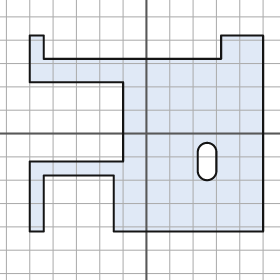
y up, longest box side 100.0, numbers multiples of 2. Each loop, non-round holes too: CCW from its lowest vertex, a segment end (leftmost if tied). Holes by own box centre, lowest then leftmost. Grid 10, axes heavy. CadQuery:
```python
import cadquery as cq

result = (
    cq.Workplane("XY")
    .moveTo(-50.0, -42.0)
    .lineTo(-44.0, -42.0)
    .lineTo(-44.0, -18.0)
    .lineTo(-14.0, -18.0)
    .lineTo(-14.0, -42.0)
    .lineTo(50.0, -42.0)
    .lineTo(50.0, 42.0)
    .lineTo(32.0, 42.0)
    .lineTo(32.0, 32.0)
    .lineTo(-44.0, 32.0)
    .lineTo(-44.0, 42.0)
    .lineTo(-50.0, 42.0)
    .lineTo(-50.0, 22.0)
    .lineTo(-10.0, 22.0)
    .lineTo(-10.0, -12.0)
    .lineTo(-50.0, -12.0)
    .close()
    .moveTo(22.0, -16.0)
    .threePointArc((26.0, -20.0), (30.0, -16.0))
    .lineTo(30.0, -8.0)
    .threePointArc((26.0, -4.0), (22.0, -8.0))
    .close()
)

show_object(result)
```